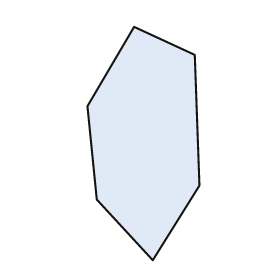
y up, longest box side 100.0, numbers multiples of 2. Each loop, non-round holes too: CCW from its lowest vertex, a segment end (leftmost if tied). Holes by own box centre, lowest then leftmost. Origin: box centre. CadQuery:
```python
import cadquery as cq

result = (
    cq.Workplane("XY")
    .moveTo(4.0, -50.0)
    .lineTo(24.0, -18.0)
    .lineTo(22.0, 38.0)
    .lineTo(-4.0, 50.0)
    .lineTo(-24.0, 16.0)
    .lineTo(-20.0, -24.0)
    .close()
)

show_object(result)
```